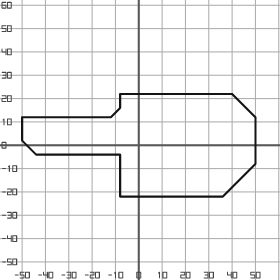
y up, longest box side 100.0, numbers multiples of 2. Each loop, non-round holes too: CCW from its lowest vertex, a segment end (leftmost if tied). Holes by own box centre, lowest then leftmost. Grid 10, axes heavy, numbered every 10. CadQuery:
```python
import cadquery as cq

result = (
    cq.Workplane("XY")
    .moveTo(-8.0, -22.0)
    .lineTo(36.0, -22.0)
    .lineTo(50.0, -8.0)
    .lineTo(50.0, 12.0)
    .lineTo(40.0, 22.0)
    .lineTo(-8.0, 22.0)
    .lineTo(-8.0, 16.0)
    .lineTo(-12.0, 12.0)
    .lineTo(-50.0, 12.0)
    .lineTo(-50.0, 2.0)
    .lineTo(-44.0, -4.0)
    .lineTo(-8.0, -4.0)
    .close()
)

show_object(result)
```